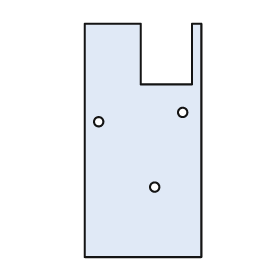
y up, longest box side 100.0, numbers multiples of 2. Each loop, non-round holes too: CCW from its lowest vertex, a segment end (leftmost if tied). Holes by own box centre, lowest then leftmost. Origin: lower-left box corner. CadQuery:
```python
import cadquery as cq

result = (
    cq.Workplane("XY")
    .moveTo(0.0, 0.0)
    .lineTo(50.0, 0.0)
    .lineTo(50.0, 100.0)
    .lineTo(46.0, 100.0)
    .lineTo(46.0, 74.0)
    .lineTo(24.0, 74.0)
    .lineTo(24.0, 100.0)
    .lineTo(0.0, 100.0)
    .close()
    .moveTo(30.0, 30.0)
    .circle(2.0)
    .moveTo(6.0, 58.0)
    .circle(2.0)
    .moveTo(42.0, 62.0)
    .circle(2.0)
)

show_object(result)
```